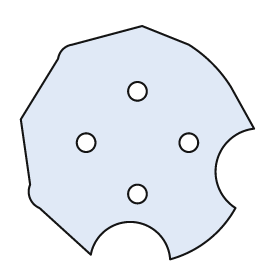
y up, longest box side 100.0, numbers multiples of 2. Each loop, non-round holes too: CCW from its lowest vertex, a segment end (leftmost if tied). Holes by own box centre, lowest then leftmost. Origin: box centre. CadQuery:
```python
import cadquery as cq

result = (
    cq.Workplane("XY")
    .moveTo(14.0, -50.0)
    .threePointArc((30.0, -42.0), (42.0, -28.0))
    .threePointArc((34.0, -8.0), (50.0, 6.0))
    .lineTo(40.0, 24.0)
    .threePointArc((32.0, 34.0), (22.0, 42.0))
    .lineTo(2.0, 50.0)
    .lineTo(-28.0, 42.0)
    .threePointArc((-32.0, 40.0), (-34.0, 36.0))
    .lineTo(-50.0, 10.0)
    .lineTo(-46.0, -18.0)
    .threePointArc((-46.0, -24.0), (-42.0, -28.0))
    .lineTo(-20.0, -48.0)
    .threePointArc((-2.0, -34.0), (14.0, -50.0))
    .close()
    .moveTo(0.0, -22.0)
    .circle(4.0)
    .moveTo(-22.0, 0.0)
    .circle(4.0)
    .moveTo(22.0, 0.0)
    .circle(4.0)
    .moveTo(0.0, 22.0)
    .circle(4.0)
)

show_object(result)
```